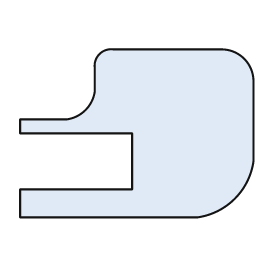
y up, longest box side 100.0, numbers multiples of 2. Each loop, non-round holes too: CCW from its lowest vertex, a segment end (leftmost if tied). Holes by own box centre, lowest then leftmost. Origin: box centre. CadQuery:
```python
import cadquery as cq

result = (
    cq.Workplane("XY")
    .moveTo(-50.0, -36.0)
    .lineTo(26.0, -36.0)
    .threePointArc((42.0, -28.0), (50.0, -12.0))
    .lineTo(50.0, 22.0)
    .threePointArc((46.0, 32.0), (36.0, 36.0))
    .lineTo(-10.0, 36.0)
    .threePointArc((-16.0, 34.0), (-18.0, 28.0))
    .lineTo(-18.0, 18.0)
    .threePointArc((-22.0, 10.0), (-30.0, 6.0))
    .lineTo(-50.0, 6.0)
    .lineTo(-50.0, 0.0)
    .lineTo(-2.0, 0.0)
    .lineTo(-2.0, -24.0)
    .lineTo(-50.0, -24.0)
    .close()
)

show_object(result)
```